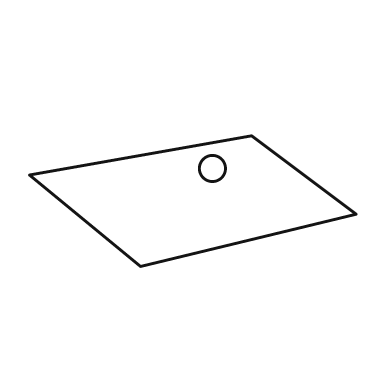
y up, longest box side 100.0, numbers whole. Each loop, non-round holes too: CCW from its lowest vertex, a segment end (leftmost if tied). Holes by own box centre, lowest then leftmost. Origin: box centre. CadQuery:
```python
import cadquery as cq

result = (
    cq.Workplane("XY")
    .moveTo(-16.0, -20.0)
    .lineTo(50.0, -4.0)
    .lineTo(18.0, 20.0)
    .lineTo(-50.0, 8.0)
    .close()
    .moveTo(6.0, 10.0)
    .circle(4.0)
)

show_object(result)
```